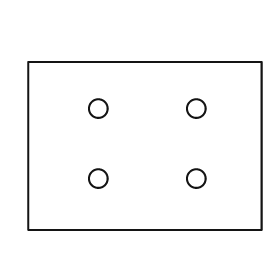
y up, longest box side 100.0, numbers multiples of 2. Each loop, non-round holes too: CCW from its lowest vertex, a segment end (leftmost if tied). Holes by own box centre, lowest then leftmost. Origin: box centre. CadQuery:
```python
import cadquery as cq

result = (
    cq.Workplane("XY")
    .moveTo(-50.0, -36.0)
    .lineTo(50.0, -36.0)
    .lineTo(50.0, 36.0)
    .lineTo(-50.0, 36.0)
    .close()
    .moveTo(-20.0, -14.0)
    .circle(4.0)
    .moveTo(22.0, -14.0)
    .circle(4.0)
    .moveTo(-20.0, 16.0)
    .circle(4.0)
    .moveTo(22.0, 16.0)
    .circle(4.0)
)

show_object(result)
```